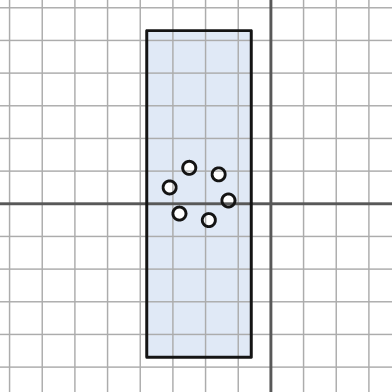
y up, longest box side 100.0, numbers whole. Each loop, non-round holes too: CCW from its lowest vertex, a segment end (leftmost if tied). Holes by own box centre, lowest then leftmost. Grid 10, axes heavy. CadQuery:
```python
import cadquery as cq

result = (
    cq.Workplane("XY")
    .moveTo(-38.0, -47.0)
    .lineTo(-6.0, -47.0)
    .lineTo(-6.0, 53.0)
    .lineTo(-38.0, 53.0)
    .close()
    .moveTo(-19.0, -5.0)
    .circle(2.0)
    .moveTo(-28.0, -3.0)
    .circle(2.0)
    .moveTo(-13.0, 1.0)
    .circle(2.0)
    .moveTo(-31.0, 5.0)
    .circle(2.0)
    .moveTo(-16.0, 9.0)
    .circle(2.0)
    .moveTo(-25.0, 11.0)
    .circle(2.0)
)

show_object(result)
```